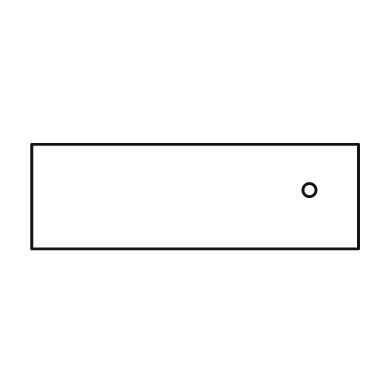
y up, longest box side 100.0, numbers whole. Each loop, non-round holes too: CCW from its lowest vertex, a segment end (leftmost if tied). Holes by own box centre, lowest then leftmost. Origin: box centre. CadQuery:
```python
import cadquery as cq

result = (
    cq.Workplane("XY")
    .moveTo(-50.0, -16.0)
    .lineTo(50.0, -16.0)
    .lineTo(50.0, 16.0)
    .lineTo(-50.0, 16.0)
    .close()
    .moveTo(35.0, 2.0)
    .circle(2.0)
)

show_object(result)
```